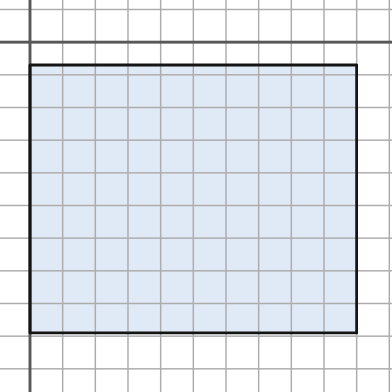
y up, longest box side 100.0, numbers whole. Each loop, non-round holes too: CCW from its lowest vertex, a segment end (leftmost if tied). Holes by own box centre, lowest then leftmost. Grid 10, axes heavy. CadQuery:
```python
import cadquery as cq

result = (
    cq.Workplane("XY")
    .moveTo(0.0, -89.0)
    .lineTo(100.0, -89.0)
    .lineTo(100.0, -7.0)
    .lineTo(0.0, -7.0)
    .close()
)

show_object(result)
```